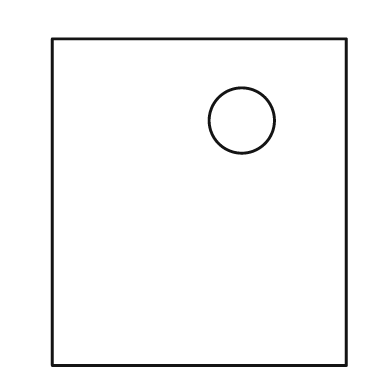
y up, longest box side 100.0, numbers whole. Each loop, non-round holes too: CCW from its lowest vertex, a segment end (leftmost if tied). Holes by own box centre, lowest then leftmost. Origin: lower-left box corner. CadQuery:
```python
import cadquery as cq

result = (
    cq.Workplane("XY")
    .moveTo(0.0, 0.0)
    .lineTo(90.0, 0.0)
    .lineTo(90.0, 100.0)
    .lineTo(0.0, 100.0)
    .close()
    .moveTo(58.0, 75.0)
    .circle(10.0)
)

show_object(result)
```